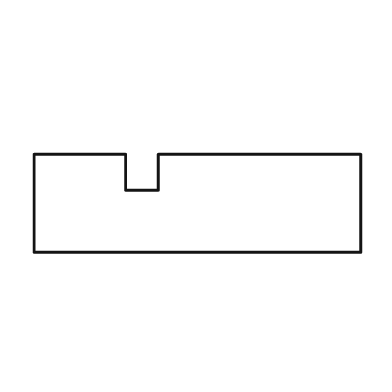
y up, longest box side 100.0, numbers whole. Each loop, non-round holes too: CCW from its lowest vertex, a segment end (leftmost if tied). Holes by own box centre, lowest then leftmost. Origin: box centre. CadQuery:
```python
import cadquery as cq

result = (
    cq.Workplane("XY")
    .moveTo(-50.0, -15.0)
    .lineTo(50.0, -15.0)
    .lineTo(50.0, 15.0)
    .lineTo(-12.0, 15.0)
    .lineTo(-12.0, 4.0)
    .lineTo(-22.0, 4.0)
    .lineTo(-22.0, 15.0)
    .lineTo(-50.0, 15.0)
    .close()
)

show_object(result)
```